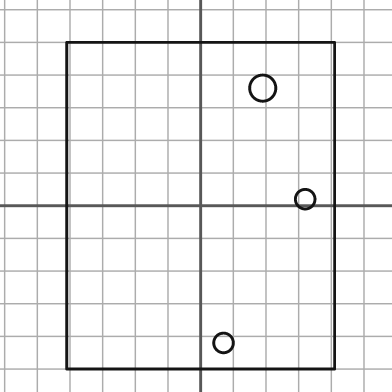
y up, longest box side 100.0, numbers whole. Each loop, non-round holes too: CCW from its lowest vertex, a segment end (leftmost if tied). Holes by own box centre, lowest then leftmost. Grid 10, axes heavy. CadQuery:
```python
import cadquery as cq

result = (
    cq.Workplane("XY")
    .moveTo(-41.0, -50.0)
    .lineTo(41.0, -50.0)
    .lineTo(41.0, 50.0)
    .lineTo(-41.0, 50.0)
    .close()
    .moveTo(7.0, -42.0)
    .circle(3.0)
    .moveTo(32.0, 2.0)
    .circle(3.0)
    .moveTo(19.0, 36.0)
    .circle(4.0)
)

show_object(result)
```